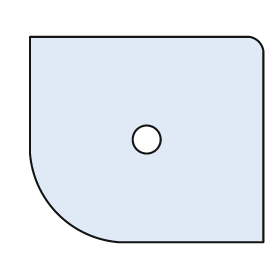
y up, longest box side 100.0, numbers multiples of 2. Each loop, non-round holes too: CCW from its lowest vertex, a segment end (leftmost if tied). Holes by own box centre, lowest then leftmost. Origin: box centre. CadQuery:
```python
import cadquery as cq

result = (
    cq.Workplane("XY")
    .moveTo(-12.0, -44.0)
    .lineTo(50.0, -44.0)
    .lineTo(50.0, 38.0)
    .threePointArc((48.0, 42.0), (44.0, 44.0))
    .lineTo(-50.0, 44.0)
    .lineTo(-50.0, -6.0)
    .threePointArc((-38.0, -32.0), (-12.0, -44.0))
    .close()
    .moveTo(0.0, 0.0)
    .circle(6.0)
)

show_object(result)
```